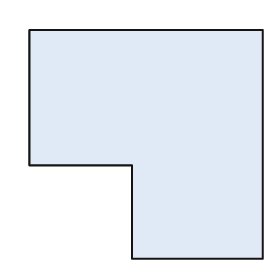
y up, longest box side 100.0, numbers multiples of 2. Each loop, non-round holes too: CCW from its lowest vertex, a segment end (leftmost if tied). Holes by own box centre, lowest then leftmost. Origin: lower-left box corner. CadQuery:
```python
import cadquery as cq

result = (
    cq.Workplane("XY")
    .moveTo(44.0, 0.0)
    .lineTo(100.0, 0.0)
    .lineTo(100.0, 98.0)
    .lineTo(0.0, 98.0)
    .lineTo(0.0, 40.0)
    .lineTo(44.0, 40.0)
    .close()
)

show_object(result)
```